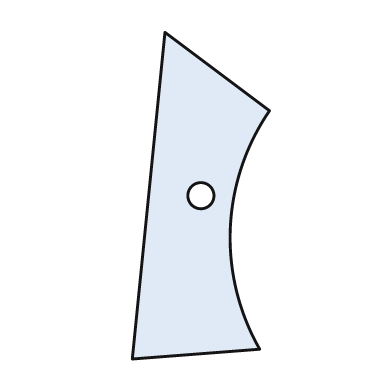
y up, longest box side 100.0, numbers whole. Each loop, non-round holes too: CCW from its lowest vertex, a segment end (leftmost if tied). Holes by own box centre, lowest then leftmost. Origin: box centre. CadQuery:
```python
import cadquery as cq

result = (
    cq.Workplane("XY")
    .moveTo(-21.0, -50.0)
    .lineTo(18.0, -47.0)
    .threePointArc((9.0, -10.0), (21.0, 26.0))
    .lineTo(-11.0, 50.0)
    .close()
    .moveTo(0.0, 0.0)
    .circle(4.0)
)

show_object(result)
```